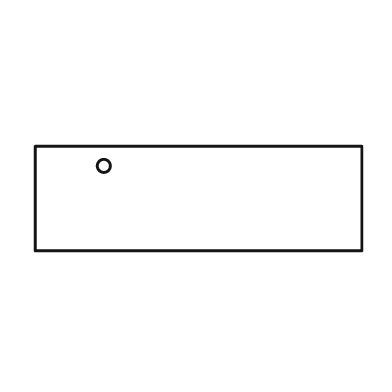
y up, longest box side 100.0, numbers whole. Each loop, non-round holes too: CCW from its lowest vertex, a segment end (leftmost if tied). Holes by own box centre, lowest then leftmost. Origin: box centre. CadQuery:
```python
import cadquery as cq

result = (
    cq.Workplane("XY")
    .moveTo(-50.0, -16.0)
    .lineTo(50.0, -16.0)
    .lineTo(50.0, 16.0)
    .lineTo(-50.0, 16.0)
    .close()
    .moveTo(-29.0, 10.0)
    .circle(2.0)
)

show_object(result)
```